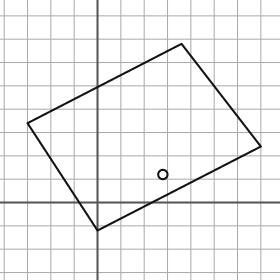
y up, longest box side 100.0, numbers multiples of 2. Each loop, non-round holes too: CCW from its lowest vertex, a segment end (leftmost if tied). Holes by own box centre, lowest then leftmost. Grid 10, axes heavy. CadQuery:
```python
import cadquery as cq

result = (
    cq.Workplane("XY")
    .moveTo(0.0, -12.0)
    .lineTo(70.0, 24.0)
    .lineTo(36.0, 68.0)
    .lineTo(-30.0, 34.0)
    .close()
    .moveTo(28.0, 12.0)
    .circle(2.0)
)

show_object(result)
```